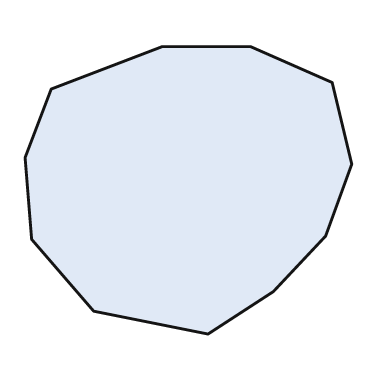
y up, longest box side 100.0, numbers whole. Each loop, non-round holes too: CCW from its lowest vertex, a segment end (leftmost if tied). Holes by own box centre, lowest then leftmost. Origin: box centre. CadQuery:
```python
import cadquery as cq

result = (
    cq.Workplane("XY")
    .moveTo(6.0, -44.0)
    .lineTo(26.0, -31.0)
    .lineTo(42.0, -14.0)
    .lineTo(50.0, 8.0)
    .lineTo(44.0, 33.0)
    .lineTo(19.0, 44.0)
    .lineTo(-8.0, 44.0)
    .lineTo(-42.0, 31.0)
    .lineTo(-50.0, 10.0)
    .lineTo(-48.0, -15.0)
    .lineTo(-29.0, -37.0)
    .close()
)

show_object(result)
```